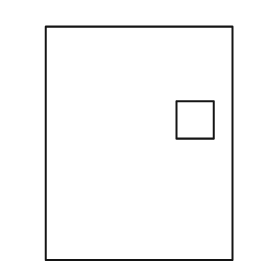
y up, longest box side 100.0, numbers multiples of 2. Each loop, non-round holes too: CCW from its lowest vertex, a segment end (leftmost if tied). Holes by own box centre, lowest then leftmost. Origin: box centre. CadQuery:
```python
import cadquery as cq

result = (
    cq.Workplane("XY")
    .moveTo(-40.0, -50.0)
    .lineTo(40.0, -50.0)
    .lineTo(40.0, 50.0)
    .lineTo(-40.0, 50.0)
    .close()
    .moveTo(16.0, 2.0)
    .lineTo(32.0, 2.0)
    .lineTo(32.0, 18.0)
    .lineTo(16.0, 18.0)
    .close()
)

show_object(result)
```